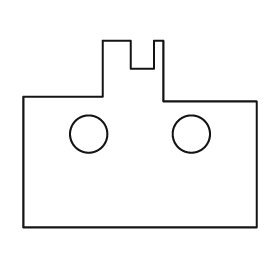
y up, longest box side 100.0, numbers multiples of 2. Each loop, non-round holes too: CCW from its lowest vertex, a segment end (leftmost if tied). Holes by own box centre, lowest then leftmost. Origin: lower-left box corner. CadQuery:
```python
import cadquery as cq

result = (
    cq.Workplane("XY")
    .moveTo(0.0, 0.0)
    .lineTo(100.0, 0.0)
    .lineTo(100.0, 54.0)
    .lineTo(60.0, 54.0)
    .lineTo(60.0, 80.0)
    .lineTo(56.0, 80.0)
    .lineTo(56.0, 68.0)
    .lineTo(46.0, 68.0)
    .lineTo(46.0, 80.0)
    .lineTo(34.0, 80.0)
    .lineTo(34.0, 56.0)
    .lineTo(0.0, 56.0)
    .close()
    .moveTo(28.0, 40.0)
    .circle(8.0)
    .moveTo(72.0, 40.0)
    .circle(8.0)
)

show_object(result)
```